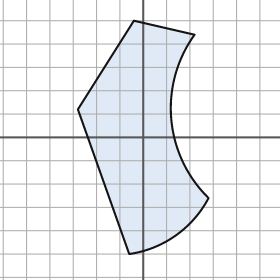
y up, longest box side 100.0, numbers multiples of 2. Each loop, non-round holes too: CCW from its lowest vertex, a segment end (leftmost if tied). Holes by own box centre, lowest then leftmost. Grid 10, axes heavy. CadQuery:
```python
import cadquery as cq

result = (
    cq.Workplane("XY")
    .moveTo(-6.0, -50.0)
    .threePointArc((14.0, -42.0), (28.0, -26.0))
    .threePointArc((12.0, 8.0), (22.0, 44.0))
    .lineTo(-4.0, 50.0)
    .lineTo(-28.0, 12.0)
    .close()
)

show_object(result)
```